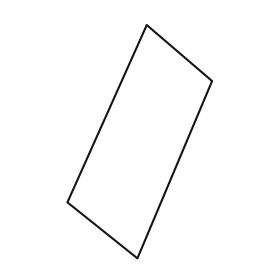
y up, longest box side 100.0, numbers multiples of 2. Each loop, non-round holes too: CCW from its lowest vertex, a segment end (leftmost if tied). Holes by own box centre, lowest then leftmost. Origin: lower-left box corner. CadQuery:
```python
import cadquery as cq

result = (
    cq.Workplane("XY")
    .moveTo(30.0, 0.0)
    .lineTo(62.0, 76.0)
    .lineTo(34.0, 100.0)
    .lineTo(0.0, 24.0)
    .close()
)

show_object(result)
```